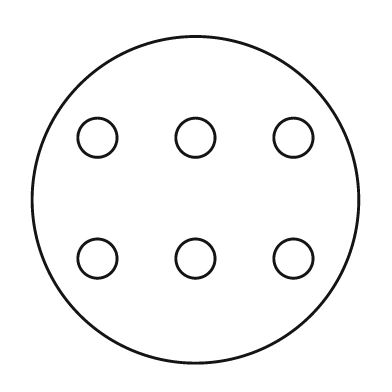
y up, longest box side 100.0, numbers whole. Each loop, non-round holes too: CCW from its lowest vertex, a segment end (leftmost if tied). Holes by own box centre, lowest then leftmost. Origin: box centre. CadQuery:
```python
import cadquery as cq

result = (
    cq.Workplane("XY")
    .moveTo(0.0, 0.0)
    .circle(50.0)
    .moveTo(-30.0, -18.0)
    .circle(6.0)
    .moveTo(0.0, -18.0)
    .circle(6.0)
    .moveTo(30.0, -18.0)
    .circle(6.0)
    .moveTo(-30.0, 19.0)
    .circle(6.0)
    .moveTo(0.0, 19.0)
    .circle(6.0)
    .moveTo(30.0, 19.0)
    .circle(6.0)
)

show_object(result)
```